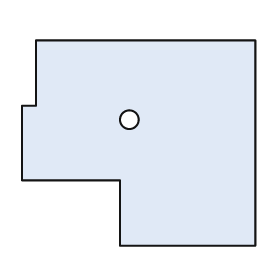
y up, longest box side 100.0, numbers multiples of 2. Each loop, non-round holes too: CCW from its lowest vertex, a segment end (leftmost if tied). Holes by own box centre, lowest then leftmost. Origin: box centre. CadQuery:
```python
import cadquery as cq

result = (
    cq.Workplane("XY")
    .moveTo(-8.0, -44.0)
    .lineTo(50.0, -44.0)
    .lineTo(50.0, 44.0)
    .lineTo(-44.0, 44.0)
    .lineTo(-44.0, 16.0)
    .lineTo(-50.0, 16.0)
    .lineTo(-50.0, -16.0)
    .lineTo(-8.0, -16.0)
    .close()
    .moveTo(-4.0, 10.0)
    .circle(4.0)
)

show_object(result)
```